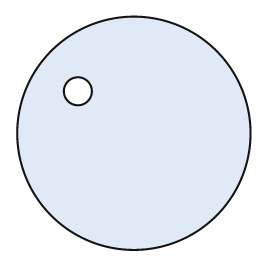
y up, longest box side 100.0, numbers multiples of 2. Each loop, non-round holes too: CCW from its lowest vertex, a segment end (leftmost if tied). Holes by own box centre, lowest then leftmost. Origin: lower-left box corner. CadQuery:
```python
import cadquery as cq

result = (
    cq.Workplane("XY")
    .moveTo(50.0, 50.0)
    .circle(50.0)
    .moveTo(26.0, 68.0)
    .circle(6.0)
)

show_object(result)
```